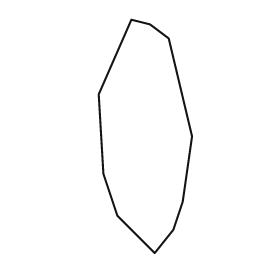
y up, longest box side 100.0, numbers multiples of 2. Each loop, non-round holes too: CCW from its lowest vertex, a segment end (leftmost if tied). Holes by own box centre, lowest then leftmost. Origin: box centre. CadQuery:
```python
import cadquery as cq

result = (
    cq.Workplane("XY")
    .moveTo(4.0, -50.0)
    .lineTo(12.0, -40.0)
    .lineTo(16.0, -28.0)
    .lineTo(20.0, 0.0)
    .lineTo(10.0, 42.0)
    .lineTo(2.0, 48.0)
    .lineTo(-6.0, 50.0)
    .lineTo(-20.0, 18.0)
    .lineTo(-18.0, -16.0)
    .lineTo(-12.0, -34.0)
    .close()
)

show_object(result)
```